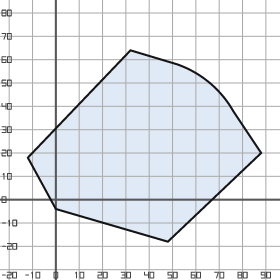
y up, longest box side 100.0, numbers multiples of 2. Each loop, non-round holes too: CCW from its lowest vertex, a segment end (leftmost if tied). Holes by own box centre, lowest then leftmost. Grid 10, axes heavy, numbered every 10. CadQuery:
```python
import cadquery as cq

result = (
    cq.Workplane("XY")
    .moveTo(48.0, -18.0)
    .lineTo(88.0, 20.0)
    .lineTo(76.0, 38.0)
    .threePointArc((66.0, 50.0), (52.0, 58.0))
    .lineTo(32.0, 64.0)
    .lineTo(-12.0, 18.0)
    .lineTo(0.0, -4.0)
    .close()
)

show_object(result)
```